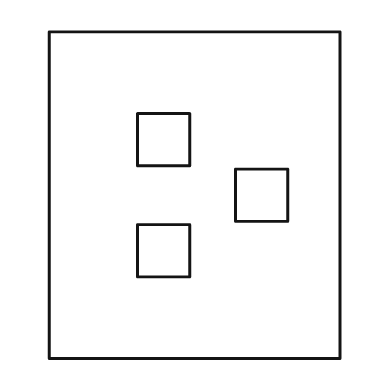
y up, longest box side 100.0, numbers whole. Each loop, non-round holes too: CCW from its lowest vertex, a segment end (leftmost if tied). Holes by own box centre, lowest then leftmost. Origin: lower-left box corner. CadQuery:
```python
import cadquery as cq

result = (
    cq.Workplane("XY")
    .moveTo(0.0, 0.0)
    .lineTo(89.0, 0.0)
    .lineTo(89.0, 100.0)
    .lineTo(0.0, 100.0)
    .close()
    .moveTo(27.0, 25.0)
    .lineTo(43.0, 25.0)
    .lineTo(43.0, 41.0)
    .lineTo(27.0, 41.0)
    .close()
    .moveTo(57.0, 42.0)
    .lineTo(73.0, 42.0)
    .lineTo(73.0, 58.0)
    .lineTo(57.0, 58.0)
    .close()
    .moveTo(27.0, 59.0)
    .lineTo(43.0, 59.0)
    .lineTo(43.0, 75.0)
    .lineTo(27.0, 75.0)
    .close()
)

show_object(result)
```